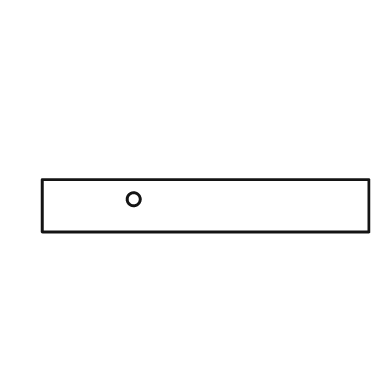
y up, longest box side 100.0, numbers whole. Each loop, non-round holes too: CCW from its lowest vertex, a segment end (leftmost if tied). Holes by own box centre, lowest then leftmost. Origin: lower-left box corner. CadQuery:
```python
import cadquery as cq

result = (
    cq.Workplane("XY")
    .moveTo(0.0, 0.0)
    .lineTo(100.0, 0.0)
    .lineTo(100.0, 16.0)
    .lineTo(0.0, 16.0)
    .close()
    .moveTo(28.0, 10.0)
    .circle(2.0)
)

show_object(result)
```